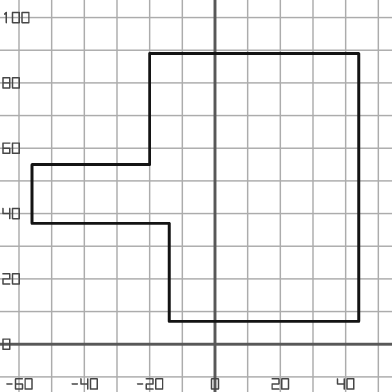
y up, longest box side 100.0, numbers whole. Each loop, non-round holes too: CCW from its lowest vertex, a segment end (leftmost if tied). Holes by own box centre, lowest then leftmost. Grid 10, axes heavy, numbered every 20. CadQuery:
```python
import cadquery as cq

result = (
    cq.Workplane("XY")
    .moveTo(-14.0, 7.0)
    .lineTo(44.0, 7.0)
    .lineTo(44.0, 89.0)
    .lineTo(-20.0, 89.0)
    .lineTo(-20.0, 55.0)
    .lineTo(-56.0, 55.0)
    .lineTo(-56.0, 37.0)
    .lineTo(-14.0, 37.0)
    .close()
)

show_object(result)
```